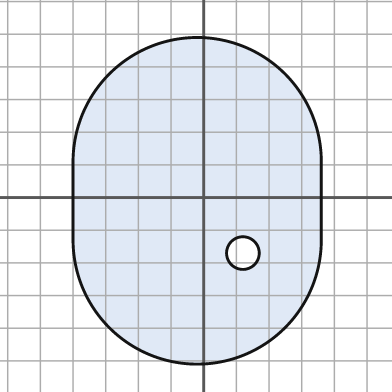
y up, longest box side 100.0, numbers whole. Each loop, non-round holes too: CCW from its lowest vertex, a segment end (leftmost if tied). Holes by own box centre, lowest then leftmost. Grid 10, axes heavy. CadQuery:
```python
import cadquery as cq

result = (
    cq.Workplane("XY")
    .moveTo(-40.0, -13.0)
    .threePointArc((-2.0, -51.0), (36.0, -13.0))
    .lineTo(36.0, 11.0)
    .threePointArc((-2.0, 49.0), (-40.0, 11.0))
    .close()
    .moveTo(12.0, -17.0)
    .circle(5.0)
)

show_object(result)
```